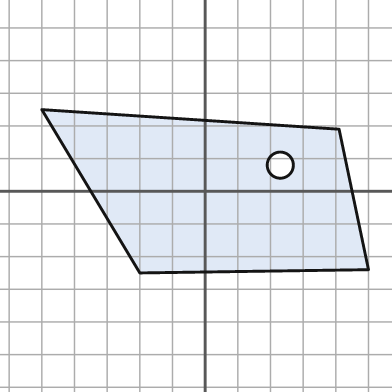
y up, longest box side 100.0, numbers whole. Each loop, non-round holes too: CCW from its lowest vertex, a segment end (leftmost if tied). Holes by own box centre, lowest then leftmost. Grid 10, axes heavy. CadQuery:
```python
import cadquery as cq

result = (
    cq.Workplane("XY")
    .moveTo(-20.0, -25.0)
    .lineTo(50.0, -24.0)
    .lineTo(41.0, 19.0)
    .lineTo(-50.0, 25.0)
    .close()
    .moveTo(23.0, 8.0)
    .circle(4.0)
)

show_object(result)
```